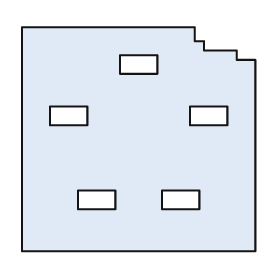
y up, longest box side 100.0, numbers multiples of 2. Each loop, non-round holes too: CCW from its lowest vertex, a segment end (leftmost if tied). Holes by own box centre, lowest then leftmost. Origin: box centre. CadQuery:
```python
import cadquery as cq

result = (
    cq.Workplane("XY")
    .moveTo(-50.0, -48.0)
    .lineTo(50.0, -48.0)
    .lineTo(50.0, 34.0)
    .lineTo(42.0, 34.0)
    .lineTo(42.0, 38.0)
    .lineTo(28.0, 38.0)
    .lineTo(28.0, 42.0)
    .lineTo(24.0, 42.0)
    .lineTo(24.0, 48.0)
    .lineTo(-50.0, 48.0)
    .close()
    .moveTo(-26.0, -30.0)
    .lineTo(-10.0, -30.0)
    .lineTo(-10.0, -22.0)
    .lineTo(-26.0, -22.0)
    .close()
    .moveTo(10.0, -30.0)
    .lineTo(26.0, -30.0)
    .lineTo(26.0, -22.0)
    .lineTo(10.0, -22.0)
    .close()
    .moveTo(-38.0, 6.0)
    .lineTo(-22.0, 6.0)
    .lineTo(-22.0, 14.0)
    .lineTo(-38.0, 14.0)
    .close()
    .moveTo(22.0, 6.0)
    .lineTo(38.0, 6.0)
    .lineTo(38.0, 14.0)
    .lineTo(22.0, 14.0)
    .close()
    .moveTo(-8.0, 28.0)
    .lineTo(8.0, 28.0)
    .lineTo(8.0, 36.0)
    .lineTo(-8.0, 36.0)
    .close()
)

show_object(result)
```